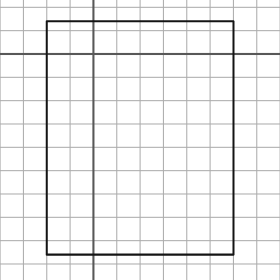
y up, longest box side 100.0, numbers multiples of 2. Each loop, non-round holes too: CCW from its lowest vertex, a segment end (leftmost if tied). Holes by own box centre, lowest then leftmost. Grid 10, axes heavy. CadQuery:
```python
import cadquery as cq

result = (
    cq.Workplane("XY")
    .moveTo(-20.0, -86.0)
    .lineTo(60.0, -86.0)
    .lineTo(60.0, 14.0)
    .lineTo(-20.0, 14.0)
    .close()
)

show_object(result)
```